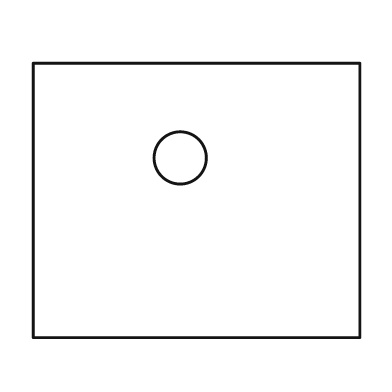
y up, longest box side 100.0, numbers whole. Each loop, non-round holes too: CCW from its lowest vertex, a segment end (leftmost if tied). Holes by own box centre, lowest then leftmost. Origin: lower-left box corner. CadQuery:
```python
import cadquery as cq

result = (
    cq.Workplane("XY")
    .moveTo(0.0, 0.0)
    .lineTo(100.0, 0.0)
    .lineTo(100.0, 84.0)
    .lineTo(0.0, 84.0)
    .close()
    .moveTo(45.0, 55.0)
    .circle(8.0)
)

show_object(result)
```